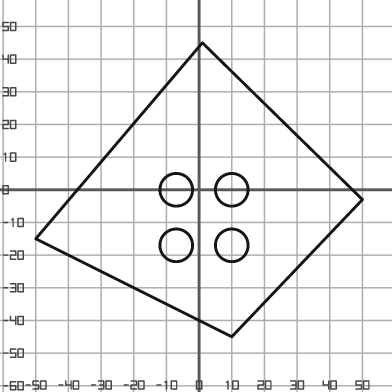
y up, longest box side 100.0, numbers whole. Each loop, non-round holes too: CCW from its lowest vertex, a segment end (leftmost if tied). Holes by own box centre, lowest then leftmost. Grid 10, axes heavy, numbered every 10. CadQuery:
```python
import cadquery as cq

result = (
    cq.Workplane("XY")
    .moveTo(10.0, -45.0)
    .lineTo(50.0, -3.0)
    .lineTo(1.0, 45.0)
    .lineTo(-50.0, -15.0)
    .close()
    .moveTo(-7.0, -17.0)
    .circle(5.0)
    .moveTo(10.0, -17.0)
    .circle(5.0)
    .moveTo(-7.0, 0.0)
    .circle(5.0)
    .moveTo(10.0, 0.0)
    .circle(5.0)
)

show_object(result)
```